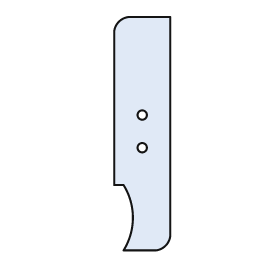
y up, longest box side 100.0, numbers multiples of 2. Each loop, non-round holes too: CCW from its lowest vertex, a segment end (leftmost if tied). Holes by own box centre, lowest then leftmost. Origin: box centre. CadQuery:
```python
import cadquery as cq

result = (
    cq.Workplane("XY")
    .moveTo(-8.0, -50.0)
    .lineTo(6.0, -50.0)
    .threePointArc((10.0, -48.0), (12.0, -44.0))
    .lineTo(12.0, 50.0)
    .lineTo(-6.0, 50.0)
    .threePointArc((-10.0, 48.0), (-12.0, 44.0))
    .lineTo(-12.0, -22.0)
    .lineTo(-8.0, -22.0)
    .threePointArc((-4.0, -36.0), (-8.0, -50.0))
    .close()
    .moveTo(0.0, -6.0)
    .circle(2.0)
    .moveTo(0.0, 8.0)
    .circle(2.0)
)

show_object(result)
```